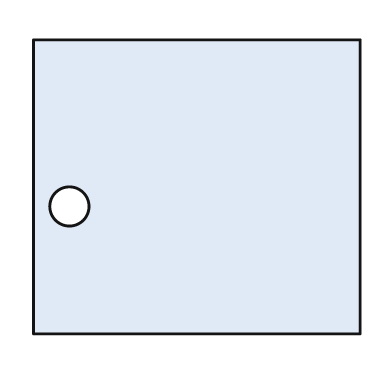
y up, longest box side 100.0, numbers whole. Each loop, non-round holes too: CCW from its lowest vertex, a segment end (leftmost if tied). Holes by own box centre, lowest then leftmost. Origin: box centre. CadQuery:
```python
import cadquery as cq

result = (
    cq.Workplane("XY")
    .moveTo(-50.0, -45.0)
    .lineTo(50.0, -45.0)
    .lineTo(50.0, 45.0)
    .lineTo(-50.0, 45.0)
    .close()
    .moveTo(-39.0, -6.0)
    .circle(6.0)
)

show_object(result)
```